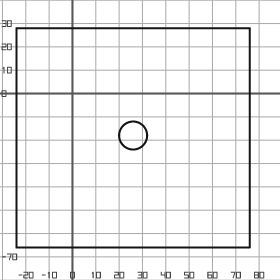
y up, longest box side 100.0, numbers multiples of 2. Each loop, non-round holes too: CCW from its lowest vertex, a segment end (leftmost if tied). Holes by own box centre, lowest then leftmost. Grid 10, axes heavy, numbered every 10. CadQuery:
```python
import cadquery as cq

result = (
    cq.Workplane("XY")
    .moveTo(-24.0, -66.0)
    .lineTo(76.0, -66.0)
    .lineTo(76.0, 28.0)
    .lineTo(-24.0, 28.0)
    .close()
    .moveTo(26.0, -18.0)
    .circle(6.0)
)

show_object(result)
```